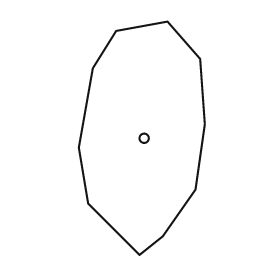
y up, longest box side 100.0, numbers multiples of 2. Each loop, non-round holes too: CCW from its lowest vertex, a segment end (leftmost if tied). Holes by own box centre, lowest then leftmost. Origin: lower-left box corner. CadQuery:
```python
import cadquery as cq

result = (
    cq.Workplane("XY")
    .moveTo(26.0, 0.0)
    .lineTo(36.0, 8.0)
    .lineTo(50.0, 28.0)
    .lineTo(54.0, 56.0)
    .lineTo(52.0, 84.0)
    .lineTo(38.0, 100.0)
    .lineTo(16.0, 96.0)
    .lineTo(6.0, 80.0)
    .lineTo(0.0, 46.0)
    .lineTo(4.0, 22.0)
    .close()
    .moveTo(28.0, 50.0)
    .circle(2.0)
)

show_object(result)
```